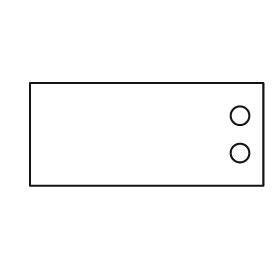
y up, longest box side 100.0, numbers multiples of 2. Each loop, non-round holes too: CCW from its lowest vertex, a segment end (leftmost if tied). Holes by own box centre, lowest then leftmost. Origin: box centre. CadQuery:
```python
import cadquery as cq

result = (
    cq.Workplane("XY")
    .moveTo(-50.0, -22.0)
    .lineTo(50.0, -22.0)
    .lineTo(50.0, 22.0)
    .lineTo(-50.0, 22.0)
    .close()
    .moveTo(40.0, -8.0)
    .circle(4.0)
    .moveTo(40.0, 8.0)
    .circle(4.0)
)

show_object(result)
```